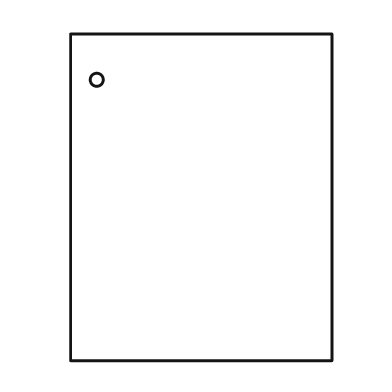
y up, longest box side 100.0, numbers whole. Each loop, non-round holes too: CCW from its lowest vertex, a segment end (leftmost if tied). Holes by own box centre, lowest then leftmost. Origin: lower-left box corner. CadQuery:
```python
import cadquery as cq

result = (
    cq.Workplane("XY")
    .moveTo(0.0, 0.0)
    .lineTo(80.0, 0.0)
    .lineTo(80.0, 100.0)
    .lineTo(0.0, 100.0)
    .close()
    .moveTo(8.0, 86.0)
    .circle(2.0)
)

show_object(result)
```